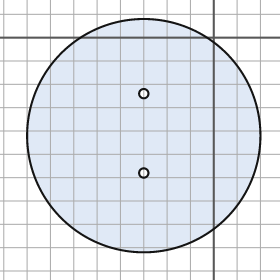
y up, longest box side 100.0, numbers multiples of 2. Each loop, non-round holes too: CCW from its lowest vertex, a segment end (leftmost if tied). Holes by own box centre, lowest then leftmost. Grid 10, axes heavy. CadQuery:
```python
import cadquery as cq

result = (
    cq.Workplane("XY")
    .moveTo(-30.0, -42.0)
    .circle(50.0)
    .moveTo(-30.0, -58.0)
    .circle(2.0)
    .moveTo(-30.0, -24.0)
    .circle(2.0)
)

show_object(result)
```